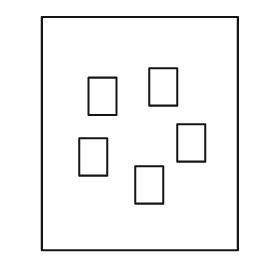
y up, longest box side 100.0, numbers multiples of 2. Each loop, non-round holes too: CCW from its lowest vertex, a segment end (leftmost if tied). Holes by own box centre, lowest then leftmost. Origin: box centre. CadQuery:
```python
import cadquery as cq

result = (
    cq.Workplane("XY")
    .moveTo(-42.0, -50.0)
    .lineTo(42.0, -50.0)
    .lineTo(42.0, 50.0)
    .lineTo(-42.0, 50.0)
    .close()
    .moveTo(-2.0, -30.0)
    .lineTo(10.0, -30.0)
    .lineTo(10.0, -14.0)
    .lineTo(-2.0, -14.0)
    .close()
    .moveTo(-26.0, -18.0)
    .lineTo(-14.0, -18.0)
    .lineTo(-14.0, -2.0)
    .lineTo(-26.0, -2.0)
    .close()
    .moveTo(16.0, -12.0)
    .lineTo(28.0, -12.0)
    .lineTo(28.0, 4.0)
    .lineTo(16.0, 4.0)
    .close()
    .moveTo(-22.0, 8.0)
    .lineTo(-10.0, 8.0)
    .lineTo(-10.0, 24.0)
    .lineTo(-22.0, 24.0)
    .close()
    .moveTo(4.0, 12.0)
    .lineTo(16.0, 12.0)
    .lineTo(16.0, 28.0)
    .lineTo(4.0, 28.0)
    .close()
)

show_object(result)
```